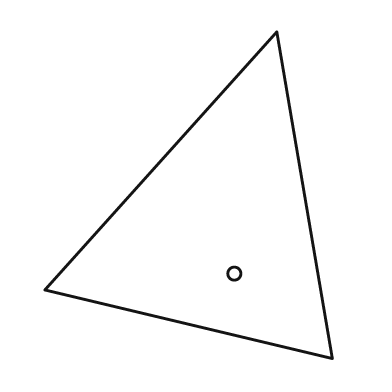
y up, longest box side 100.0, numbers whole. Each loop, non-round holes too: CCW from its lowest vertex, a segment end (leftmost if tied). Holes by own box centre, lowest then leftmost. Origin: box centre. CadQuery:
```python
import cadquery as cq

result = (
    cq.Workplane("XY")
    .moveTo(44.0, -50.0)
    .lineTo(27.0, 50.0)
    .lineTo(-44.0, -29.0)
    .close()
    .moveTo(14.0, -24.0)
    .circle(2.0)
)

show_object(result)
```